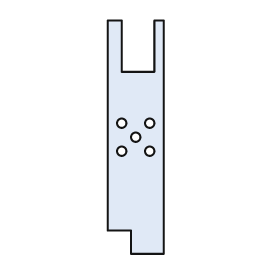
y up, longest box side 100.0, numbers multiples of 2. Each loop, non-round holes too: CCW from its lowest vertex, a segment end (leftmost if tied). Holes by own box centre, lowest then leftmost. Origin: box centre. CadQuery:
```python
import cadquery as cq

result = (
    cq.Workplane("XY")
    .moveTo(-2.0, -50.0)
    .lineTo(12.0, -50.0)
    .lineTo(12.0, 50.0)
    .lineTo(8.0, 50.0)
    .lineTo(8.0, 28.0)
    .lineTo(-6.0, 28.0)
    .lineTo(-6.0, 50.0)
    .lineTo(-12.0, 50.0)
    .lineTo(-12.0, -40.0)
    .lineTo(-2.0, -40.0)
    .close()
    .moveTo(-6.0, -6.0)
    .circle(2.0)
    .moveTo(6.0, -6.0)
    .circle(2.0)
    .moveTo(0.0, 0.0)
    .circle(2.0)
    .moveTo(-6.0, 6.0)
    .circle(2.0)
    .moveTo(6.0, 6.0)
    .circle(2.0)
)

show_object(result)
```